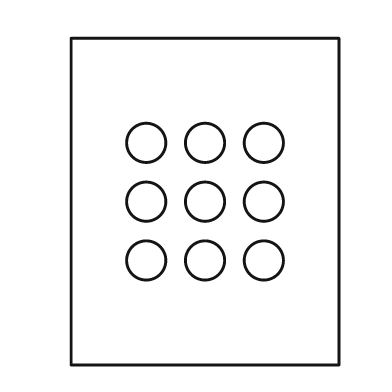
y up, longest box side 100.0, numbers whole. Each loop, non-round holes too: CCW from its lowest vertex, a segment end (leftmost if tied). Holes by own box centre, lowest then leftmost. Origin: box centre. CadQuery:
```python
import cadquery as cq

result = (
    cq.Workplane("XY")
    .moveTo(-41.0, -50.0)
    .lineTo(41.0, -50.0)
    .lineTo(41.0, 50.0)
    .lineTo(-41.0, 50.0)
    .close()
    .moveTo(-18.0, -18.0)
    .circle(6.0)
    .moveTo(0.0, -18.0)
    .circle(6.0)
    .moveTo(18.0, -18.0)
    .circle(6.0)
    .moveTo(-18.0, 0.0)
    .circle(6.0)
    .moveTo(0.0, 0.0)
    .circle(6.0)
    .moveTo(18.0, 0.0)
    .circle(6.0)
    .moveTo(-18.0, 18.0)
    .circle(6.0)
    .moveTo(0.0, 18.0)
    .circle(6.0)
    .moveTo(18.0, 18.0)
    .circle(6.0)
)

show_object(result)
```